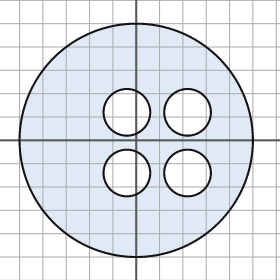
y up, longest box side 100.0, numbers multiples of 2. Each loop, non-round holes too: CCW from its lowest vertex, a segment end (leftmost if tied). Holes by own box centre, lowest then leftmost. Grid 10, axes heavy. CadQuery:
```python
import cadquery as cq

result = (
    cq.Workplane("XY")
    .moveTo(0.0, 0.0)
    .circle(50.0)
    .moveTo(-4.0, -14.0)
    .circle(10.0)
    .moveTo(22.0, -14.0)
    .circle(10.0)
    .moveTo(-4.0, 12.0)
    .circle(10.0)
    .moveTo(22.0, 12.0)
    .circle(10.0)
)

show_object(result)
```